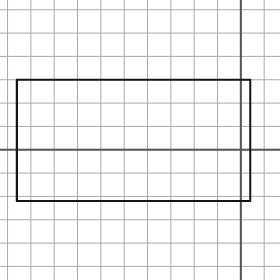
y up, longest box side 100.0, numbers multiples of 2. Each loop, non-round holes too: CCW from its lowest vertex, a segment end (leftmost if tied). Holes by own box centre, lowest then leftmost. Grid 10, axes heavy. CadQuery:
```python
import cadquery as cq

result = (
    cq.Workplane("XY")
    .moveTo(-96.0, -22.0)
    .lineTo(4.0, -22.0)
    .lineTo(4.0, 30.0)
    .lineTo(-96.0, 30.0)
    .close()
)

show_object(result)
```